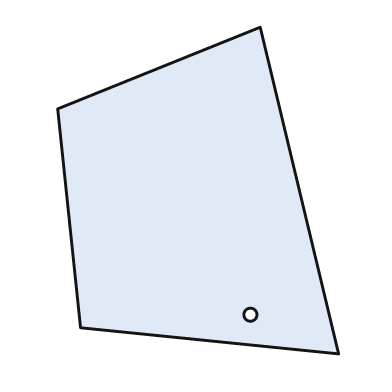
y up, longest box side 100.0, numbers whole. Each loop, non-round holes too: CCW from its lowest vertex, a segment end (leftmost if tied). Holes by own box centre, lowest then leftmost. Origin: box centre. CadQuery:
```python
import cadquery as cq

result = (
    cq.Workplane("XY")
    .moveTo(43.0, -50.0)
    .lineTo(19.0, 50.0)
    .lineTo(-43.0, 25.0)
    .lineTo(-36.0, -42.0)
    .close()
    .moveTo(16.0, -38.0)
    .circle(2.0)
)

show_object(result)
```